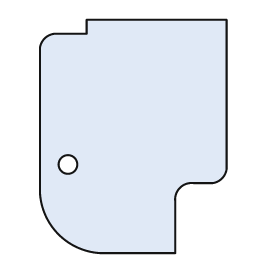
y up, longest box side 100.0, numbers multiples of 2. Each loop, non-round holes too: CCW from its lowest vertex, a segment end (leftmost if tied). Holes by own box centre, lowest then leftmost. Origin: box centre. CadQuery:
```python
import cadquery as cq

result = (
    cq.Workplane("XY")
    .moveTo(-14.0, -50.0)
    .lineTo(18.0, -50.0)
    .lineTo(18.0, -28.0)
    .threePointArc((20.0, -22.0), (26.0, -20.0))
    .lineTo(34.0, -20.0)
    .threePointArc((38.0, -18.0), (40.0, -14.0))
    .lineTo(40.0, 50.0)
    .lineTo(-20.0, 50.0)
    .lineTo(-20.0, 44.0)
    .lineTo(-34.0, 44.0)
    .threePointArc((-38.0, 42.0), (-40.0, 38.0))
    .lineTo(-40.0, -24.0)
    .threePointArc((-32.0, -42.0), (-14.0, -50.0))
    .close()
    .moveTo(-28.0, -12.0)
    .circle(4.0)
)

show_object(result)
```